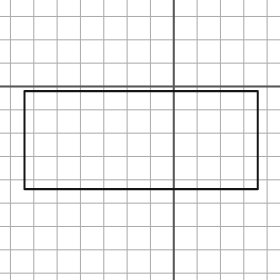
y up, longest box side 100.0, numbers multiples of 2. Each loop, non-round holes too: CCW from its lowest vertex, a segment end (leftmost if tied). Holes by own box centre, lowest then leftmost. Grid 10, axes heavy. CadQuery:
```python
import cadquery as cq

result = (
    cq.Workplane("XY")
    .moveTo(-64.0, -44.0)
    .lineTo(36.0, -44.0)
    .lineTo(36.0, -2.0)
    .lineTo(-64.0, -2.0)
    .close()
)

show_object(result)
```